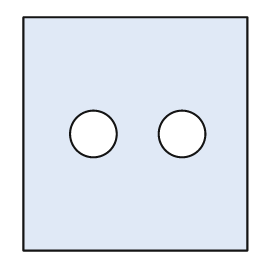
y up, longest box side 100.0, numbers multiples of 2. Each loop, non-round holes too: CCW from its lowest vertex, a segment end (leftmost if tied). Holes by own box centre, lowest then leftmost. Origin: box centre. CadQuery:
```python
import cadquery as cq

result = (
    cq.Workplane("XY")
    .moveTo(-48.0, -50.0)
    .lineTo(48.0, -50.0)
    .lineTo(48.0, 50.0)
    .lineTo(-48.0, 50.0)
    .close()
    .moveTo(-18.0, 0.0)
    .circle(10.0)
    .moveTo(20.0, 0.0)
    .circle(10.0)
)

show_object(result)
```